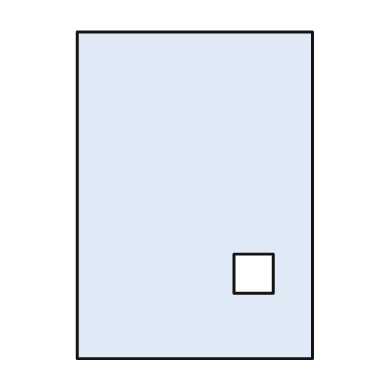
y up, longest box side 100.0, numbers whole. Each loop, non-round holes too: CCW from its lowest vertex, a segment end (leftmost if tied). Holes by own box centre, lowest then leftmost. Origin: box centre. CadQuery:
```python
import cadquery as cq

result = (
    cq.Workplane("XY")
    .moveTo(-36.0, -50.0)
    .lineTo(36.0, -50.0)
    .lineTo(36.0, 50.0)
    .lineTo(-36.0, 50.0)
    .close()
    .moveTo(12.0, -30.0)
    .lineTo(24.0, -30.0)
    .lineTo(24.0, -18.0)
    .lineTo(12.0, -18.0)
    .close()
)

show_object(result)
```